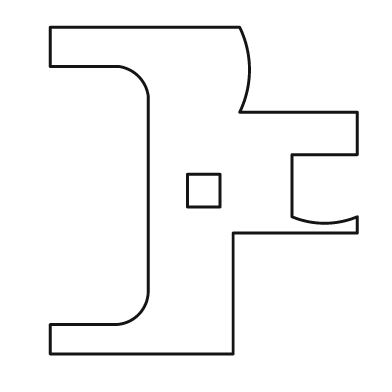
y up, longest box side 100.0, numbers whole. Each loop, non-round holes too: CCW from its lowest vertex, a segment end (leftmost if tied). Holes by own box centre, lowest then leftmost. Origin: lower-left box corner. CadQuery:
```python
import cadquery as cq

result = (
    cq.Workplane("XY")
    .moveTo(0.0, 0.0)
    .lineTo(56.0, 0.0)
    .lineTo(56.0, 37.0)
    .lineTo(94.0, 37.0)
    .lineTo(94.0, 42.0)
    .threePointArc((84.0, 40.0), (74.0, 42.0))
    .lineTo(74.0, 61.0)
    .lineTo(94.0, 61.0)
    .lineTo(94.0, 74.0)
    .lineTo(58.0, 74.0)
    .threePointArc((61.0, 87.0), (58.0, 100.0))
    .lineTo(0.0, 100.0)
    .lineTo(0.0, 88.0)
    .lineTo(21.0, 88.0)
    .threePointArc((27.0, 85.0), (30.0, 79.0))
    .lineTo(30.0, 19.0)
    .threePointArc((27.0, 12.0), (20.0, 9.0))
    .lineTo(0.0, 9.0)
    .close()
    .moveTo(42.0, 45.0)
    .lineTo(52.0, 45.0)
    .lineTo(52.0, 55.0)
    .lineTo(42.0, 55.0)
    .close()
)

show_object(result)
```